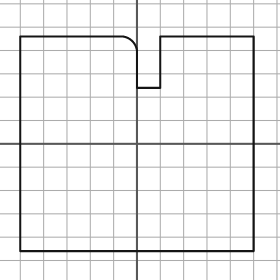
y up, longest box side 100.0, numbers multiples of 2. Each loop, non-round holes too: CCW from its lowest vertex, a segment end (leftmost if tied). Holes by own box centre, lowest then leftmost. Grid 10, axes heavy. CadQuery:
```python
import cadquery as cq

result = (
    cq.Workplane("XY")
    .moveTo(-50.0, -46.0)
    .lineTo(50.0, -46.0)
    .lineTo(50.0, 46.0)
    .lineTo(10.0, 46.0)
    .lineTo(10.0, 24.0)
    .lineTo(0.0, 24.0)
    .lineTo(0.0, 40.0)
    .threePointArc((-2.0, 44.0), (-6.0, 46.0))
    .lineTo(-50.0, 46.0)
    .close()
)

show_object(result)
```